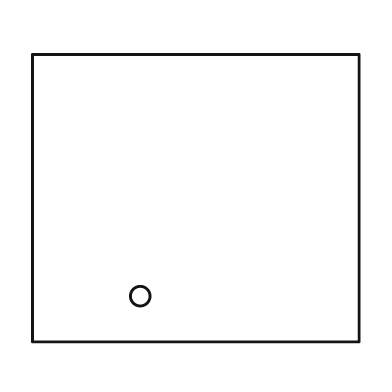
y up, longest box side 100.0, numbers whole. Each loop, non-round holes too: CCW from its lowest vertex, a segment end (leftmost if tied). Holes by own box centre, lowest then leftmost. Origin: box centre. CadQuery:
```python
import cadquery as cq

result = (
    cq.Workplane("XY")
    .moveTo(-50.0, -44.0)
    .lineTo(50.0, -44.0)
    .lineTo(50.0, 44.0)
    .lineTo(-50.0, 44.0)
    .close()
    .moveTo(-17.0, -30.0)
    .circle(3.0)
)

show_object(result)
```